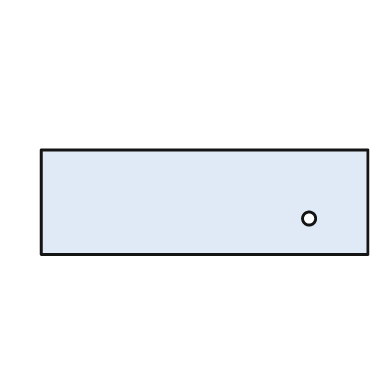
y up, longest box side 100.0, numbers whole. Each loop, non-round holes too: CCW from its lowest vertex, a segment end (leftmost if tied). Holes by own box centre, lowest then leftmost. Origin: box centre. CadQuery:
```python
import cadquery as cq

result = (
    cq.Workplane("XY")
    .moveTo(-50.0, -16.0)
    .lineTo(50.0, -16.0)
    .lineTo(50.0, 16.0)
    .lineTo(-50.0, 16.0)
    .close()
    .moveTo(32.0, -5.0)
    .circle(2.0)
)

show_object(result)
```